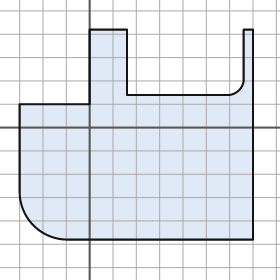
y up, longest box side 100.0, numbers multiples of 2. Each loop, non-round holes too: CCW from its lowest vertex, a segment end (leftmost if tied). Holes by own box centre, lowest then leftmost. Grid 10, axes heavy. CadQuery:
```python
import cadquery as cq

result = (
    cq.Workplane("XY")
    .moveTo(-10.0, -48.0)
    .lineTo(70.0, -48.0)
    .lineTo(70.0, 42.0)
    .lineTo(66.0, 42.0)
    .lineTo(66.0, 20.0)
    .threePointArc((64.0, 16.0), (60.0, 14.0))
    .lineTo(16.0, 14.0)
    .lineTo(16.0, 42.0)
    .lineTo(0.0, 42.0)
    .lineTo(0.0, 10.0)
    .lineTo(-30.0, 10.0)
    .lineTo(-30.0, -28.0)
    .threePointArc((-24.0, -42.0), (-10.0, -48.0))
    .close()
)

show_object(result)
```